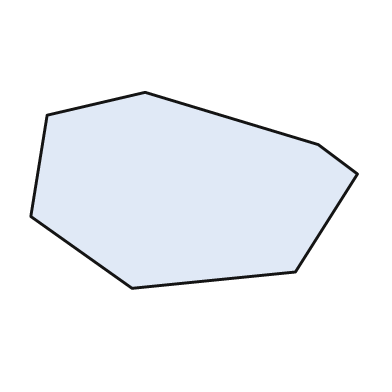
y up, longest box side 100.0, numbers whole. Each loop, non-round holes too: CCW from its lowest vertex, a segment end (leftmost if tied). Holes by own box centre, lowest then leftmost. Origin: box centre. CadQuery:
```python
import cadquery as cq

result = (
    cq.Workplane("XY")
    .moveTo(-19.0, -30.0)
    .lineTo(31.0, -25.0)
    .lineTo(50.0, 5.0)
    .lineTo(38.0, 14.0)
    .lineTo(-15.0, 30.0)
    .lineTo(-45.0, 23.0)
    .lineTo(-50.0, -8.0)
    .close()
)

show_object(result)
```